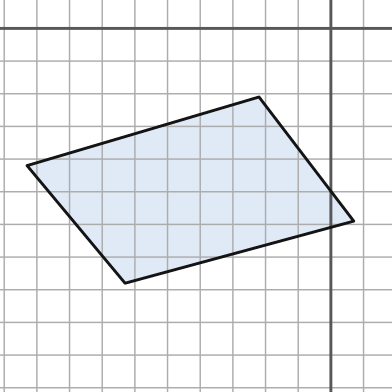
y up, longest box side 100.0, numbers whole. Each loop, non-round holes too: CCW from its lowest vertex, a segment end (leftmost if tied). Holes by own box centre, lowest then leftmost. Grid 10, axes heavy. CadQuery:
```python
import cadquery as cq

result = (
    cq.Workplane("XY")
    .moveTo(-63.0, -78.0)
    .lineTo(7.0, -59.0)
    .lineTo(-22.0, -21.0)
    .lineTo(-93.0, -42.0)
    .close()
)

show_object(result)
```